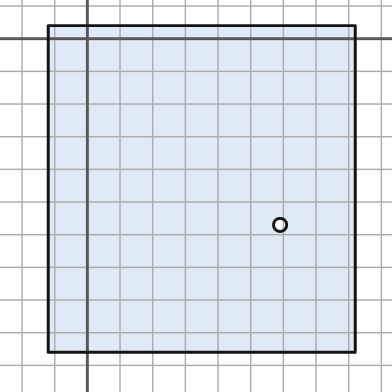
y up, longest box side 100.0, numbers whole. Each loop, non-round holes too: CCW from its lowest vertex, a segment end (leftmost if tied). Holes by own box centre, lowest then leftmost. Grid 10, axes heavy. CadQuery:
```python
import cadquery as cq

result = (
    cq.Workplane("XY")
    .moveTo(-12.0, -96.0)
    .lineTo(82.0, -96.0)
    .lineTo(82.0, 4.0)
    .lineTo(-12.0, 4.0)
    .close()
    .moveTo(59.0, -57.0)
    .circle(2.0)
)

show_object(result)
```